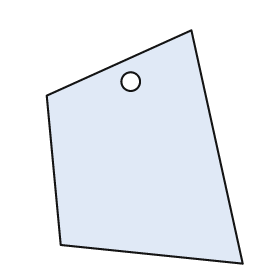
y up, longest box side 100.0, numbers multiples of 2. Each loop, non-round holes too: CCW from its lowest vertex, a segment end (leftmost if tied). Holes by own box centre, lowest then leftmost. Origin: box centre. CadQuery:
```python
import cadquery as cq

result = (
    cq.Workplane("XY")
    .moveTo(42.0, -50.0)
    .lineTo(20.0, 50.0)
    .lineTo(-42.0, 22.0)
    .lineTo(-36.0, -42.0)
    .close()
    .moveTo(-6.0, 28.0)
    .circle(4.0)
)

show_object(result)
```